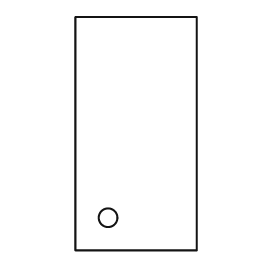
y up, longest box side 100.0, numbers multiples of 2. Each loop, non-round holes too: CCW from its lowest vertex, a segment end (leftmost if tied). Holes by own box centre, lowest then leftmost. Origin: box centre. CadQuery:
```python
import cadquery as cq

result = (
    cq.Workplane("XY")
    .moveTo(-26.0, -50.0)
    .lineTo(26.0, -50.0)
    .lineTo(26.0, 50.0)
    .lineTo(-26.0, 50.0)
    .close()
    .moveTo(-12.0, -36.0)
    .circle(4.0)
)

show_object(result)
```